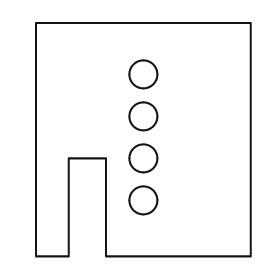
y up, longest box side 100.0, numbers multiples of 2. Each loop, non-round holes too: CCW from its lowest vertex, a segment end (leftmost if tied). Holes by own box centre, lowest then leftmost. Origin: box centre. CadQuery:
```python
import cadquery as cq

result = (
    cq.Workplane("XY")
    .moveTo(-46.0, -50.0)
    .lineTo(-32.0, -50.0)
    .lineTo(-32.0, -8.0)
    .lineTo(-16.0, -8.0)
    .lineTo(-16.0, -50.0)
    .lineTo(46.0, -50.0)
    .lineTo(46.0, 50.0)
    .lineTo(-46.0, 50.0)
    .close()
    .moveTo(0.0, -26.0)
    .circle(6.0)
    .moveTo(0.0, -8.0)
    .circle(6.0)
    .moveTo(0.0, 10.0)
    .circle(6.0)
    .moveTo(0.0, 28.0)
    .circle(6.0)
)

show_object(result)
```